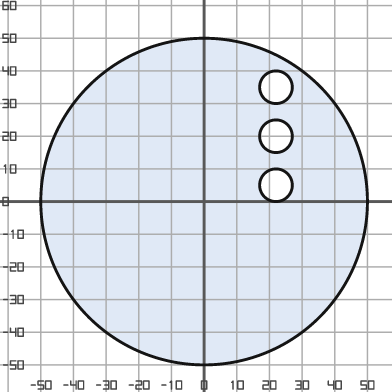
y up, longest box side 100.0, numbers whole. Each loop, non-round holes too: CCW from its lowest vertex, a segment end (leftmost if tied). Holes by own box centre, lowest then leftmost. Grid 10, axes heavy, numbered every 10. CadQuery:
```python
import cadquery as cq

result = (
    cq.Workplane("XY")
    .moveTo(0.0, 0.0)
    .circle(50.0)
    .moveTo(22.0, 5.0)
    .circle(5.0)
    .moveTo(22.0, 20.0)
    .circle(5.0)
    .moveTo(22.0, 35.0)
    .circle(5.0)
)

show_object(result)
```